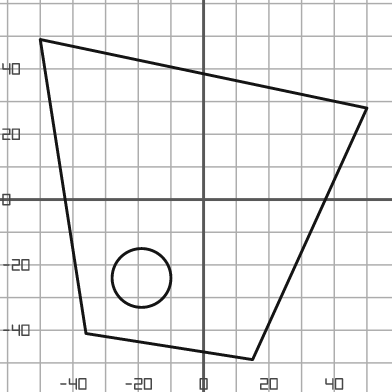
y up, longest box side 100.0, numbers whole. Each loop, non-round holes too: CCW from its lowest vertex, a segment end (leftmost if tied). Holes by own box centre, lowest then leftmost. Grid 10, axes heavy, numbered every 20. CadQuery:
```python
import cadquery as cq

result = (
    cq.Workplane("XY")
    .moveTo(15.0, -49.0)
    .lineTo(50.0, 28.0)
    .lineTo(-50.0, 49.0)
    .lineTo(-36.0, -41.0)
    .close()
    .moveTo(-19.0, -24.0)
    .circle(9.0)
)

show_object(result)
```